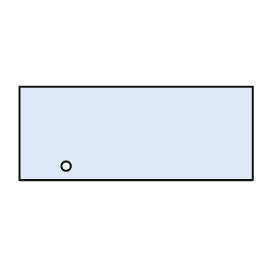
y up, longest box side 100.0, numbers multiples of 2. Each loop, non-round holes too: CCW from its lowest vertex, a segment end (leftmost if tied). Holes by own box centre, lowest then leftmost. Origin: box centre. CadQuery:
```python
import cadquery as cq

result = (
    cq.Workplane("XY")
    .moveTo(-50.0, -20.0)
    .lineTo(50.0, -20.0)
    .lineTo(50.0, 20.0)
    .lineTo(-50.0, 20.0)
    .close()
    .moveTo(-30.0, -14.0)
    .circle(2.0)
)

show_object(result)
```